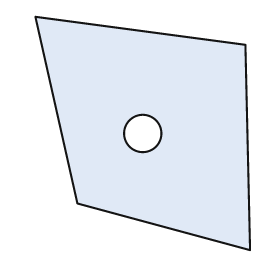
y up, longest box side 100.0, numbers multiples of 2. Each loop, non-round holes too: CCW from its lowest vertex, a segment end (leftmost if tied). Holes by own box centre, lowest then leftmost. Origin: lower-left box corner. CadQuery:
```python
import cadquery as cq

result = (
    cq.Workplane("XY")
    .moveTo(92.0, 0.0)
    .lineTo(90.0, 88.0)
    .lineTo(0.0, 100.0)
    .lineTo(18.0, 20.0)
    .close()
    .moveTo(46.0, 50.0)
    .circle(8.0)
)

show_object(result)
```